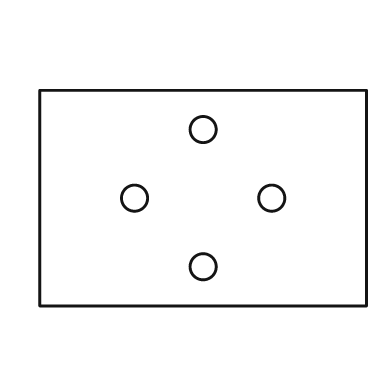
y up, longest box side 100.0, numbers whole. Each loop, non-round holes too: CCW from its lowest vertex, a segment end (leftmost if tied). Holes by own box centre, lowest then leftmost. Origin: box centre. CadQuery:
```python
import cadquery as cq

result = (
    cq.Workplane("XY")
    .moveTo(-50.0, -33.0)
    .lineTo(50.0, -33.0)
    .lineTo(50.0, 33.0)
    .lineTo(-50.0, 33.0)
    .close()
    .moveTo(0.0, -21.0)
    .circle(4.0)
    .moveTo(-21.0, 0.0)
    .circle(4.0)
    .moveTo(21.0, 0.0)
    .circle(4.0)
    .moveTo(0.0, 21.0)
    .circle(4.0)
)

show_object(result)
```